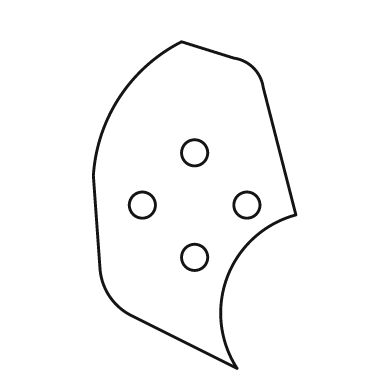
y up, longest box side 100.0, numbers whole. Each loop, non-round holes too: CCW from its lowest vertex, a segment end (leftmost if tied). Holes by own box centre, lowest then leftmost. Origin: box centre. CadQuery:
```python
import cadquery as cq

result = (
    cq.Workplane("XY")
    .moveTo(13.0, -50.0)
    .threePointArc((10.0, -22.0), (31.0, -3.0))
    .lineTo(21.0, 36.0)
    .threePointArc((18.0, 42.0), (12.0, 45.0))
    .lineTo(-4.0, 50.0)
    .threePointArc((-23.0, 33.0), (-31.0, 9.0))
    .lineTo(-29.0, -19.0)
    .threePointArc((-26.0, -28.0), (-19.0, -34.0))
    .close()
    .moveTo(0.0, -16.0)
    .circle(4.0)
    .moveTo(-16.0, 0.0)
    .circle(4.0)
    .moveTo(16.0, 0.0)
    .circle(4.0)
    .moveTo(0.0, 16.0)
    .circle(4.0)
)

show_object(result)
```